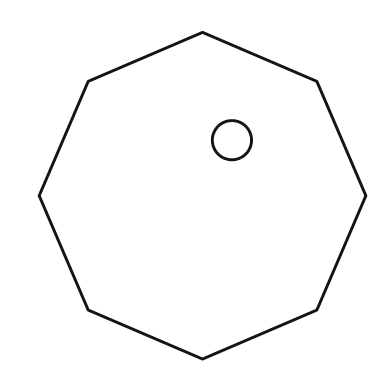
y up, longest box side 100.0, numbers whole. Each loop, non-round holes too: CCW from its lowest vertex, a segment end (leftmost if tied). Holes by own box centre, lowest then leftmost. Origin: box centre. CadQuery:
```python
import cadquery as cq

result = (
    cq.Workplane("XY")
    .moveTo(0.0, -50.0)
    .lineTo(35.0, -35.0)
    .lineTo(50.0, 0.0)
    .lineTo(35.0, 35.0)
    .lineTo(0.0, 50.0)
    .lineTo(-35.0, 35.0)
    .lineTo(-50.0, 0.0)
    .lineTo(-35.0, -35.0)
    .close()
    .moveTo(9.0, 17.0)
    .circle(6.0)
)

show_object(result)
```